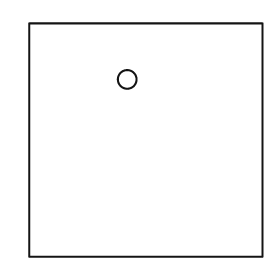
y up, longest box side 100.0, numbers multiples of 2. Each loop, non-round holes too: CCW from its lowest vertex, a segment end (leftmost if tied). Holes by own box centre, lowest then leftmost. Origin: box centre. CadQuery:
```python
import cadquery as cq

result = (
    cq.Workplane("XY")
    .moveTo(-50.0, -50.0)
    .lineTo(50.0, -50.0)
    .lineTo(50.0, 50.0)
    .lineTo(-50.0, 50.0)
    .close()
    .moveTo(-8.0, 26.0)
    .circle(4.0)
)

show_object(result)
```